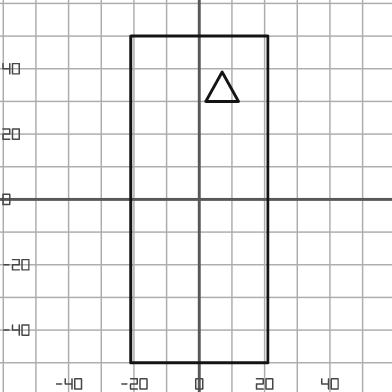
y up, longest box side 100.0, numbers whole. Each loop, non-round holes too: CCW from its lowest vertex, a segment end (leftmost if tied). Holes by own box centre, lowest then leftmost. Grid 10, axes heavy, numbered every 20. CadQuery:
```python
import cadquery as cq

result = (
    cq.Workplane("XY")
    .moveTo(-21.0, -50.0)
    .lineTo(21.0, -50.0)
    .lineTo(21.0, 50.0)
    .lineTo(-21.0, 50.0)
    .close()
    .moveTo(2.0, 30.0)
    .lineTo(12.0, 30.0)
    .lineTo(7.0, 39.0)
    .close()
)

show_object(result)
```